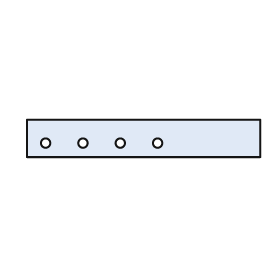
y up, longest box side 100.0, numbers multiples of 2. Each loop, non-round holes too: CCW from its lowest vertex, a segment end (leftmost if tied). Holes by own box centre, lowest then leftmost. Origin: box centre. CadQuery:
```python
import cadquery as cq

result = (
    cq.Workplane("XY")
    .moveTo(-50.0, -8.0)
    .lineTo(50.0, -8.0)
    .lineTo(50.0, 8.0)
    .lineTo(-50.0, 8.0)
    .close()
    .moveTo(-42.0, -2.0)
    .circle(2.0)
    .moveTo(-26.0, -2.0)
    .circle(2.0)
    .moveTo(-10.0, -2.0)
    .circle(2.0)
    .moveTo(6.0, -2.0)
    .circle(2.0)
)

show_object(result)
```